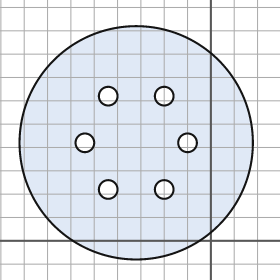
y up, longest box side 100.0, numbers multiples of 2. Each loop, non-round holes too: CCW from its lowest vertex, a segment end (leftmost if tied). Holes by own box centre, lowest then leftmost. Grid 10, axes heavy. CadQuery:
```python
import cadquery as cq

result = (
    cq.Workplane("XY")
    .moveTo(-32.0, 42.0)
    .circle(50.0)
    .moveTo(-44.0, 22.0)
    .circle(4.0)
    .moveTo(-20.0, 22.0)
    .circle(4.0)
    .moveTo(-54.0, 42.0)
    .circle(4.0)
    .moveTo(-10.0, 42.0)
    .circle(4.0)
    .moveTo(-44.0, 62.0)
    .circle(4.0)
    .moveTo(-20.0, 62.0)
    .circle(4.0)
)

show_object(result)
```